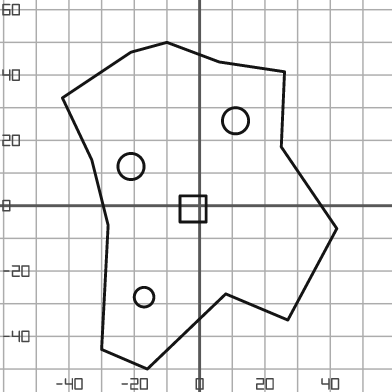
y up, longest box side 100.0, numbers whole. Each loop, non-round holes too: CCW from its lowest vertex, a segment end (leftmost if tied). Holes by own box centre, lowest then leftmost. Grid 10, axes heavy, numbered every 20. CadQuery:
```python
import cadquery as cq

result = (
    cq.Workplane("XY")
    .moveTo(-16.0, -50.0)
    .lineTo(8.0, -27.0)
    .lineTo(27.0, -35.0)
    .lineTo(42.0, -7.0)
    .lineTo(25.0, 18.0)
    .lineTo(26.0, 41.0)
    .lineTo(6.0, 44.0)
    .lineTo(-10.0, 50.0)
    .lineTo(-21.0, 47.0)
    .lineTo(-42.0, 33.0)
    .lineTo(-33.0, 14.0)
    .lineTo(-28.0, -6.0)
    .lineTo(-30.0, -44.0)
    .close()
    .moveTo(-17.0, -28.0)
    .circle(3.0)
    .moveTo(-6.0, -5.0)
    .lineTo(2.0, -5.0)
    .lineTo(2.0, 3.0)
    .lineTo(-6.0, 3.0)
    .close()
    .moveTo(-21.0, 12.0)
    .circle(4.0)
    .moveTo(11.0, 26.0)
    .circle(4.0)
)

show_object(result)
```